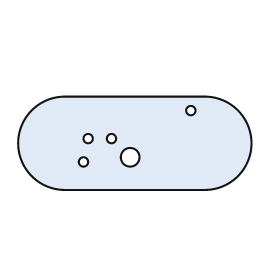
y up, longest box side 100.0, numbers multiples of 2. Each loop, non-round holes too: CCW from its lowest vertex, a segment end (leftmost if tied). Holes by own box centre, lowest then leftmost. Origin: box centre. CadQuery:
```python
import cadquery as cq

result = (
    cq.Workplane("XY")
    .moveTo(-30.0, -20.0)
    .lineTo(30.0, -20.0)
    .threePointArc((50.0, 0.0), (30.0, 20.0))
    .lineTo(-30.0, 20.0)
    .threePointArc((-50.0, 0.0), (-30.0, -20.0))
    .close()
    .moveTo(-22.0, -8.0)
    .circle(2.0)
    .moveTo(-2.0, -6.0)
    .circle(4.0)
    .moveTo(-20.0, 2.0)
    .circle(2.0)
    .moveTo(-10.0, 2.0)
    .circle(2.0)
    .moveTo(24.0, 14.0)
    .circle(2.0)
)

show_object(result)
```